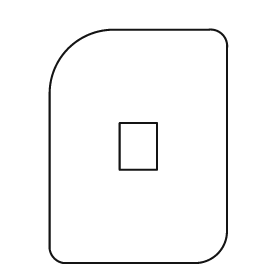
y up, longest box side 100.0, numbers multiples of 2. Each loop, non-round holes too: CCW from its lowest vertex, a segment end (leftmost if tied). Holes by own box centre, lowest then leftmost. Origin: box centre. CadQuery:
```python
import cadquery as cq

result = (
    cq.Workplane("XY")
    .moveTo(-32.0, -50.0)
    .lineTo(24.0, -50.0)
    .threePointArc((34.0, -46.0), (38.0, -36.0))
    .lineTo(38.0, 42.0)
    .threePointArc((36.0, 48.0), (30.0, 50.0))
    .lineTo(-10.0, 50.0)
    .threePointArc((-30.0, 42.0), (-38.0, 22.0))
    .lineTo(-38.0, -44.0)
    .threePointArc((-36.0, -48.0), (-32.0, -50.0))
    .close()
    .moveTo(-8.0, -10.0)
    .lineTo(8.0, -10.0)
    .lineTo(8.0, 10.0)
    .lineTo(-8.0, 10.0)
    .close()
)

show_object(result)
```